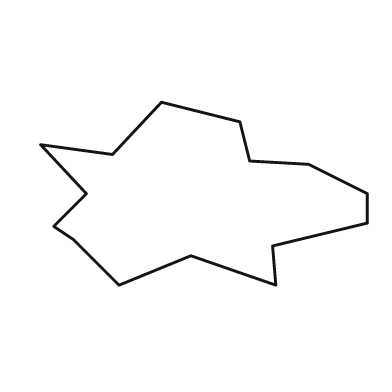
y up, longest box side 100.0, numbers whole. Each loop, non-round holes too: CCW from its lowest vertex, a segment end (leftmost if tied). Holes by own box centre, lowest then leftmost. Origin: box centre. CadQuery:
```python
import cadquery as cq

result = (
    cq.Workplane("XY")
    .moveTo(-26.0, -28.0)
    .lineTo(-4.0, -19.0)
    .lineTo(22.0, -28.0)
    .lineTo(21.0, -16.0)
    .lineTo(50.0, -9.0)
    .lineTo(50.0, 0.0)
    .lineTo(32.0, 9.0)
    .lineTo(14.0, 10.0)
    .lineTo(11.0, 22.0)
    .lineTo(-13.0, 28.0)
    .lineTo(-28.0, 12.0)
    .lineTo(-50.0, 15.0)
    .lineTo(-36.0, 0.0)
    .lineTo(-46.0, -10.0)
    .lineTo(-40.0, -14.0)
    .close()
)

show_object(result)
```